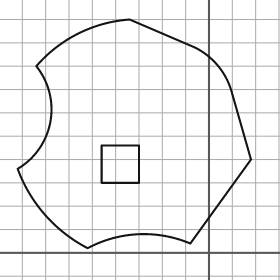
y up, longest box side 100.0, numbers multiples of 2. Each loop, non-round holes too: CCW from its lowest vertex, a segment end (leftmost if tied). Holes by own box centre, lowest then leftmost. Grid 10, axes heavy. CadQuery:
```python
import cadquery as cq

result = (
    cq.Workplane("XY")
    .moveTo(-52.0, 2.0)
    .threePointArc((-30.0, 8.0), (-8.0, 4.0))
    .lineTo(18.0, 40.0)
    .lineTo(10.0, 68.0)
    .threePointArc((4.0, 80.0), (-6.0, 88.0))
    .lineTo(-34.0, 100.0)
    .threePointArc((-56.0, 94.0), (-74.0, 80.0))
    .threePointArc((-68.0, 56.0), (-82.0, 36.0))
    .threePointArc((-70.0, 16.0), (-52.0, 2.0))
    .close()
    .moveTo(-46.0, 30.0)
    .lineTo(-30.0, 30.0)
    .lineTo(-30.0, 46.0)
    .lineTo(-46.0, 46.0)
    .close()
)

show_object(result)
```